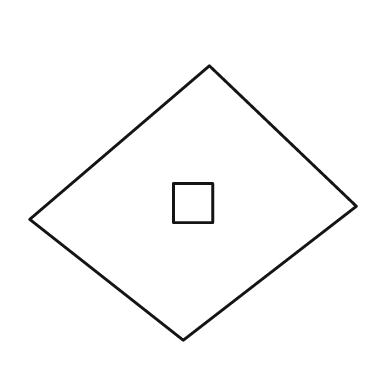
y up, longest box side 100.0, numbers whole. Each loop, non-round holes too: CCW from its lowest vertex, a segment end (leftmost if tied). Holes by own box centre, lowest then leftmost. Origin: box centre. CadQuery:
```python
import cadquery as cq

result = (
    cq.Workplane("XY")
    .moveTo(-3.0, -42.0)
    .lineTo(50.0, -1.0)
    .lineTo(5.0, 42.0)
    .lineTo(-50.0, -5.0)
    .close()
    .moveTo(-6.0, -6.0)
    .lineTo(6.0, -6.0)
    .lineTo(6.0, 6.0)
    .lineTo(-6.0, 6.0)
    .close()
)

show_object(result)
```